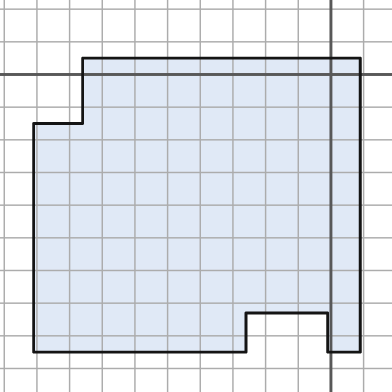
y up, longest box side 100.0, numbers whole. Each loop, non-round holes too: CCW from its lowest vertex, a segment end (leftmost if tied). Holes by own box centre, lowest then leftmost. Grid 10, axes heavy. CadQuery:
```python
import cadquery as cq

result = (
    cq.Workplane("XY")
    .moveTo(-91.0, -85.0)
    .lineTo(-26.0, -85.0)
    .lineTo(-26.0, -73.0)
    .lineTo(-1.0, -73.0)
    .lineTo(-1.0, -85.0)
    .lineTo(9.0, -85.0)
    .lineTo(9.0, 5.0)
    .lineTo(-76.0, 5.0)
    .lineTo(-76.0, -15.0)
    .lineTo(-91.0, -15.0)
    .close()
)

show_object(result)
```